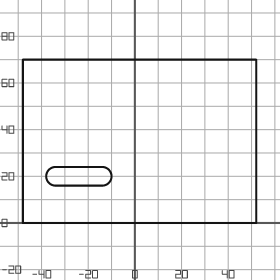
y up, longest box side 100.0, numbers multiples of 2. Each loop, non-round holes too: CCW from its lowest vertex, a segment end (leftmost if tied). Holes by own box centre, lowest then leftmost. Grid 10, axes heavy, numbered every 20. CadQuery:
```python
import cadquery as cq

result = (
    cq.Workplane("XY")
    .moveTo(-48.0, 0.0)
    .lineTo(52.0, 0.0)
    .lineTo(52.0, 70.0)
    .lineTo(-48.0, 70.0)
    .close()
    .moveTo(-34.0, 16.0)
    .lineTo(-14.0, 16.0)
    .threePointArc((-10.0, 20.0), (-14.0, 24.0))
    .lineTo(-34.0, 24.0)
    .threePointArc((-38.0, 20.0), (-34.0, 16.0))
    .close()
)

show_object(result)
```